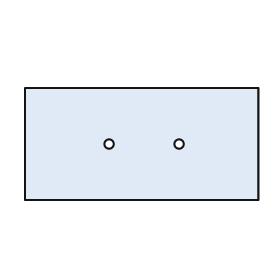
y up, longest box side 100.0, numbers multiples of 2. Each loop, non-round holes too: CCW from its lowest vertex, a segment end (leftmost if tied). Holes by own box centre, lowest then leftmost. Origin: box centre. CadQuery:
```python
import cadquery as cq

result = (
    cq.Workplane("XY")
    .moveTo(-50.0, -24.0)
    .lineTo(50.0, -24.0)
    .lineTo(50.0, 24.0)
    .lineTo(-50.0, 24.0)
    .close()
    .moveTo(-14.0, 0.0)
    .circle(2.0)
    .moveTo(16.0, 0.0)
    .circle(2.0)
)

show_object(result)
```